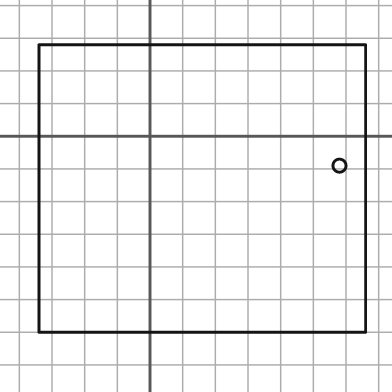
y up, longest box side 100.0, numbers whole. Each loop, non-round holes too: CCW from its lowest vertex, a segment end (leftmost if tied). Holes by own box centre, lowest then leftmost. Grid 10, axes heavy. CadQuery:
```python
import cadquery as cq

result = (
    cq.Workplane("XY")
    .moveTo(-34.0, -60.0)
    .lineTo(66.0, -60.0)
    .lineTo(66.0, 28.0)
    .lineTo(-34.0, 28.0)
    .close()
    .moveTo(58.0, -9.0)
    .circle(2.0)
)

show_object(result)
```